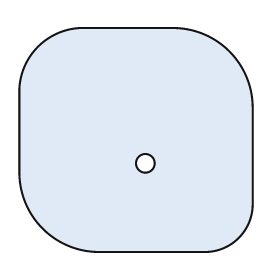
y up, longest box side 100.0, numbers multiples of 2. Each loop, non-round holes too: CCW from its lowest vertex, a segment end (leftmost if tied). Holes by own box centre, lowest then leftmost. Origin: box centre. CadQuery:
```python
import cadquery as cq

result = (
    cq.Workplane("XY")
    .moveTo(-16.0, -48.0)
    .lineTo(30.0, -48.0)
    .threePointArc((44.0, -42.0), (50.0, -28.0))
    .lineTo(50.0, 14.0)
    .threePointArc((40.0, 38.0), (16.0, 48.0))
    .lineTo(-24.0, 48.0)
    .threePointArc((-42.0, 40.0), (-50.0, 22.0))
    .lineTo(-50.0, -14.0)
    .threePointArc((-40.0, -38.0), (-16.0, -48.0))
    .close()
    .moveTo(4.0, -10.0)
    .circle(4.0)
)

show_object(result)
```